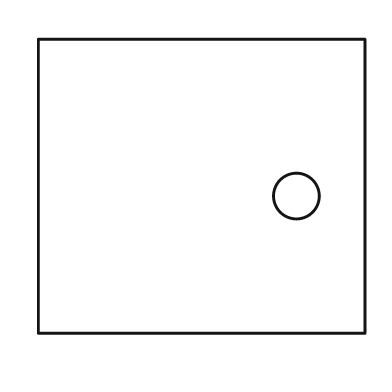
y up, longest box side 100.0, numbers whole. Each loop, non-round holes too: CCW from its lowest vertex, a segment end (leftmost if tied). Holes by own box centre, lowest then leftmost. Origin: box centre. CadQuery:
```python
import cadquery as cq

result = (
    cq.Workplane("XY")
    .moveTo(-50.0, -45.0)
    .lineTo(50.0, -45.0)
    .lineTo(50.0, 45.0)
    .lineTo(-50.0, 45.0)
    .close()
    .moveTo(29.0, -3.0)
    .circle(7.0)
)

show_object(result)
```